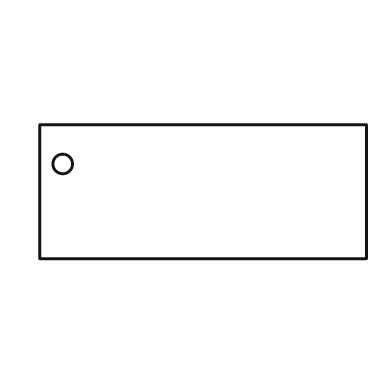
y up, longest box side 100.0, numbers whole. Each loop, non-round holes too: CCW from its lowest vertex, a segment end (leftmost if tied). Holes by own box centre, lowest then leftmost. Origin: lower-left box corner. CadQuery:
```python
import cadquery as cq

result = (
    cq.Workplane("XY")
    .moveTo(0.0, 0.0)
    .lineTo(100.0, 0.0)
    .lineTo(100.0, 41.0)
    .lineTo(0.0, 41.0)
    .close()
    .moveTo(7.0, 29.0)
    .circle(3.0)
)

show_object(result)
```